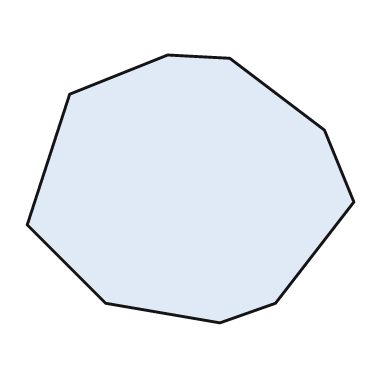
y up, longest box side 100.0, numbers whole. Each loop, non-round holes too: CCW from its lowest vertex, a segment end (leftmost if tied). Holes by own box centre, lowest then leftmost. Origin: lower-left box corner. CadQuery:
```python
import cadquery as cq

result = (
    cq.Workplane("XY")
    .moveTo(59.0, 0.0)
    .lineTo(76.0, 6.0)
    .lineTo(100.0, 37.0)
    .lineTo(91.0, 59.0)
    .lineTo(62.0, 81.0)
    .lineTo(43.0, 82.0)
    .lineTo(13.0, 70.0)
    .lineTo(0.0, 30.0)
    .lineTo(24.0, 6.0)
    .close()
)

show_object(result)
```